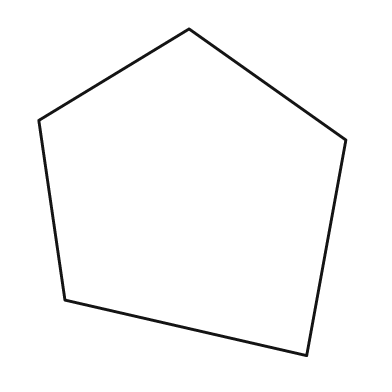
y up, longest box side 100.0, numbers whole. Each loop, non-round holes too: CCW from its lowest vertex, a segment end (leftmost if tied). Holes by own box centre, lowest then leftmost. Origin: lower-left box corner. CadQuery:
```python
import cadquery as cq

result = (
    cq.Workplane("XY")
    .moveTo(82.0, 0.0)
    .lineTo(94.0, 66.0)
    .lineTo(46.0, 100.0)
    .lineTo(0.0, 72.0)
    .lineTo(8.0, 17.0)
    .close()
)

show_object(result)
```